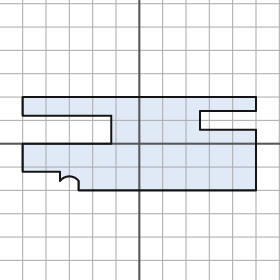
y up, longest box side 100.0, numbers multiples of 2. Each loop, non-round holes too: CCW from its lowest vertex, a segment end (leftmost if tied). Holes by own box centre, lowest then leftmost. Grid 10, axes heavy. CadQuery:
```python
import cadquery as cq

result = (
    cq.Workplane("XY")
    .moveTo(-26.0, -20.0)
    .lineTo(50.0, -20.0)
    .lineTo(50.0, 6.0)
    .lineTo(26.0, 6.0)
    .lineTo(26.0, 14.0)
    .lineTo(50.0, 14.0)
    .lineTo(50.0, 20.0)
    .lineTo(-50.0, 20.0)
    .lineTo(-50.0, 12.0)
    .lineTo(-12.0, 12.0)
    .lineTo(-12.0, 0.0)
    .lineTo(-50.0, 0.0)
    .lineTo(-50.0, -12.0)
    .lineTo(-34.0, -12.0)
    .lineTo(-34.0, -16.0)
    .threePointArc((-30.0, -14.0), (-26.0, -16.0))
    .close()
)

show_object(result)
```